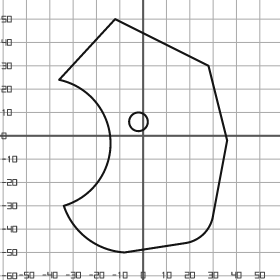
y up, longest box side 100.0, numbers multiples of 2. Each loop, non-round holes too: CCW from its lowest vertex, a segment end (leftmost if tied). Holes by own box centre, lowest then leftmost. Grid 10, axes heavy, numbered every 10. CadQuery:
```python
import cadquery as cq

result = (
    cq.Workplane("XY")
    .moveTo(-8.0, -50.0)
    .lineTo(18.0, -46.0)
    .threePointArc((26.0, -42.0), (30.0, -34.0))
    .lineTo(36.0, -2.0)
    .lineTo(28.0, 30.0)
    .lineTo(-12.0, 50.0)
    .lineTo(-36.0, 24.0)
    .threePointArc((-14.0, -2.0), (-34.0, -30.0))
    .threePointArc((-24.0, -44.0), (-8.0, -50.0))
    .close()
    .moveTo(-2.0, 6.0)
    .circle(4.0)
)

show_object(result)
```